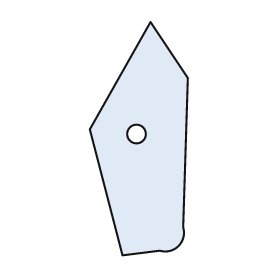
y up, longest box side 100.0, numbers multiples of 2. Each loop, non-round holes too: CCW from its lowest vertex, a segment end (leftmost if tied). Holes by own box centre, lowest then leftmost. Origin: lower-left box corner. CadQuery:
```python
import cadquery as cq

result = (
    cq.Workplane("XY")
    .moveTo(14.0, 0.0)
    .lineTo(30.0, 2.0)
    .threePointArc((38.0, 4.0), (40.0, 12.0))
    .lineTo(42.0, 76.0)
    .lineTo(26.0, 100.0)
    .lineTo(0.0, 54.0)
    .close()
    .moveTo(20.0, 52.0)
    .circle(4.0)
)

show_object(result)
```